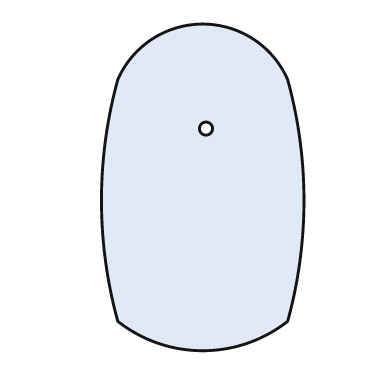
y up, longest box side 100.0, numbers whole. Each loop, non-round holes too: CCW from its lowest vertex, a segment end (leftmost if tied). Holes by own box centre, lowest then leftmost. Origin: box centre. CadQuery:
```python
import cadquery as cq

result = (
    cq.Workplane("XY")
    .moveTo(-26.0, -41.0)
    .threePointArc((0.0, -50.0), (26.0, -41.0))
    .threePointArc((31.0, -4.0), (26.0, 33.0))
    .threePointArc((0.0, 50.0), (-26.0, 33.0))
    .threePointArc((-31.0, -4.0), (-26.0, -41.0))
    .close()
    .moveTo(1.0, 18.0)
    .circle(2.0)
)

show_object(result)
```